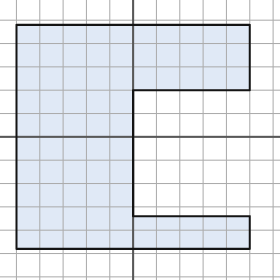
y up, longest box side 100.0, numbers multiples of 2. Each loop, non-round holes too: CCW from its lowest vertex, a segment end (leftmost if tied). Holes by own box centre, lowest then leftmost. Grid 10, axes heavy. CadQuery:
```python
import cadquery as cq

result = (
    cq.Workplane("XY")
    .moveTo(-50.0, -48.0)
    .lineTo(50.0, -48.0)
    .lineTo(50.0, -34.0)
    .lineTo(0.0, -34.0)
    .lineTo(0.0, 20.0)
    .lineTo(50.0, 20.0)
    .lineTo(50.0, 48.0)
    .lineTo(-50.0, 48.0)
    .close()
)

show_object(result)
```